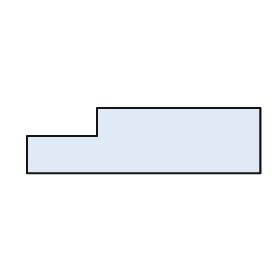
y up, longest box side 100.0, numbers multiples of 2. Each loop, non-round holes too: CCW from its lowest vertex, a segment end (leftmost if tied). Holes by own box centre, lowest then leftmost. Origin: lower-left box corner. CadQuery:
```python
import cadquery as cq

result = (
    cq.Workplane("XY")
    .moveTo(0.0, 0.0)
    .lineTo(100.0, 0.0)
    .lineTo(100.0, 28.0)
    .lineTo(30.0, 28.0)
    .lineTo(30.0, 16.0)
    .lineTo(0.0, 16.0)
    .close()
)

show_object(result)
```